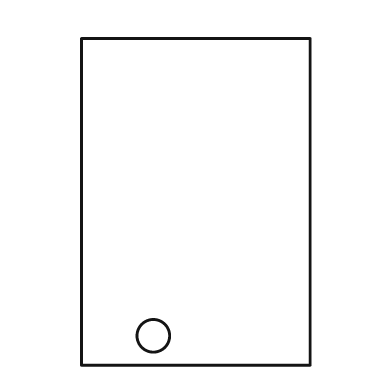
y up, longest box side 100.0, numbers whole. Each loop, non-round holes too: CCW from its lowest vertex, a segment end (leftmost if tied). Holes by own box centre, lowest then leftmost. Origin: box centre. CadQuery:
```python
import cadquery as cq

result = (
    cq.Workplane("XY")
    .moveTo(-35.0, -50.0)
    .lineTo(35.0, -50.0)
    .lineTo(35.0, 50.0)
    .lineTo(-35.0, 50.0)
    .close()
    .moveTo(-13.0, -41.0)
    .circle(5.0)
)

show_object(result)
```